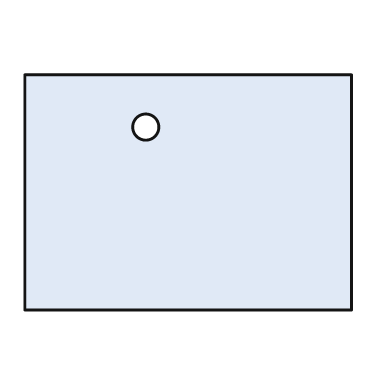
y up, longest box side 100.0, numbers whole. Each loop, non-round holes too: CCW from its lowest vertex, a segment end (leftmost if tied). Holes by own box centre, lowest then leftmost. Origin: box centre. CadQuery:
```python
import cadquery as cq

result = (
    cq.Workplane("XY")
    .moveTo(-50.0, -36.0)
    .lineTo(50.0, -36.0)
    .lineTo(50.0, 36.0)
    .lineTo(-50.0, 36.0)
    .close()
    .moveTo(-13.0, 20.0)
    .circle(4.0)
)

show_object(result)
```